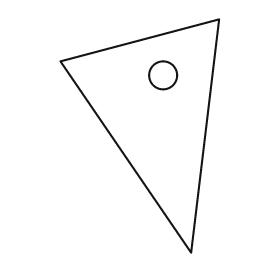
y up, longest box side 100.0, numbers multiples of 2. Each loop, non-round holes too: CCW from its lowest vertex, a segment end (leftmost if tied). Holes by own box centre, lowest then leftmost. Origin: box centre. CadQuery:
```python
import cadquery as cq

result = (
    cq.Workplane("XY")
    .moveTo(22.0, -50.0)
    .lineTo(34.0, 50.0)
    .lineTo(-34.0, 32.0)
    .close()
    .moveTo(10.0, 26.0)
    .circle(6.0)
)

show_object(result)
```